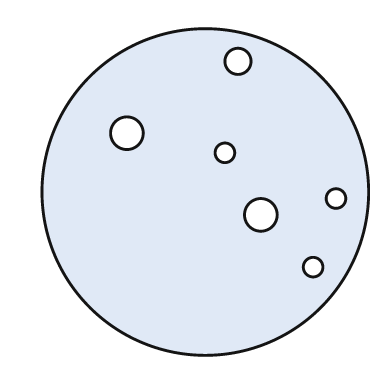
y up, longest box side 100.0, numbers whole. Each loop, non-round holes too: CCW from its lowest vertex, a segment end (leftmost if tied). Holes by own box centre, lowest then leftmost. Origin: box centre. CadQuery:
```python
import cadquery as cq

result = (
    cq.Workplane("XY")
    .moveTo(0.0, 0.0)
    .circle(50.0)
    .moveTo(33.0, -23.0)
    .circle(3.0)
    .moveTo(17.0, -7.0)
    .circle(5.0)
    .moveTo(40.0, -2.0)
    .circle(3.0)
    .moveTo(6.0, 12.0)
    .circle(3.0)
    .moveTo(-24.0, 18.0)
    .circle(5.0)
    .moveTo(10.0, 40.0)
    .circle(4.0)
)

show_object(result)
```